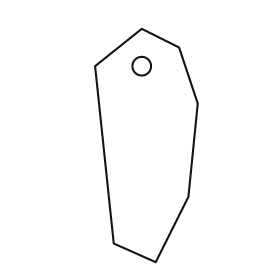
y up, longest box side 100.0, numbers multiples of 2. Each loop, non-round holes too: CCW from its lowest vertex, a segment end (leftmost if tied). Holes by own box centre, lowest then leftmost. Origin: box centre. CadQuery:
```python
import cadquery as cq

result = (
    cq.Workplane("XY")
    .moveTo(4.0, -50.0)
    .lineTo(18.0, -22.0)
    .lineTo(22.0, 18.0)
    .lineTo(14.0, 42.0)
    .lineTo(-2.0, 50.0)
    .lineTo(-22.0, 34.0)
    .lineTo(-14.0, -42.0)
    .close()
    .moveTo(-2.0, 34.0)
    .circle(4.0)
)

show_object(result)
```